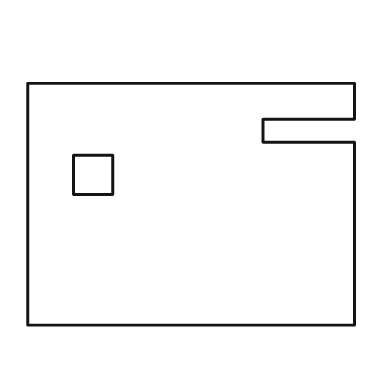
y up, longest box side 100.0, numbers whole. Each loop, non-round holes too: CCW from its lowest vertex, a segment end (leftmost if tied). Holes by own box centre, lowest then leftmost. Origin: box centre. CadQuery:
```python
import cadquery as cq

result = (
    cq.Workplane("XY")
    .moveTo(-50.0, -37.0)
    .lineTo(50.0, -37.0)
    .lineTo(50.0, 19.0)
    .lineTo(22.0, 19.0)
    .lineTo(22.0, 26.0)
    .lineTo(50.0, 26.0)
    .lineTo(50.0, 37.0)
    .lineTo(-50.0, 37.0)
    .close()
    .moveTo(-36.0, 3.0)
    .lineTo(-24.0, 3.0)
    .lineTo(-24.0, 15.0)
    .lineTo(-36.0, 15.0)
    .close()
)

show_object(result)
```